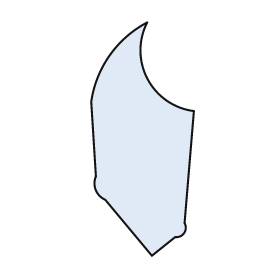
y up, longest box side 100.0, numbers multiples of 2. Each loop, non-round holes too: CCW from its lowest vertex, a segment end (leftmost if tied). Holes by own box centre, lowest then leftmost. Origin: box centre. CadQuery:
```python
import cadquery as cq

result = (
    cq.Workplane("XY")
    .moveTo(4.0, -50.0)
    .lineTo(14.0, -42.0)
    .threePointArc((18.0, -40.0), (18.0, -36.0))
    .lineTo(22.0, 12.0)
    .threePointArc((2.0, 26.0), (2.0, 50.0))
    .threePointArc((-14.0, 36.0), (-22.0, 16.0))
    .lineTo(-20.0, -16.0)
    .threePointArc((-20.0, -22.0), (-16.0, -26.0))
    .close()
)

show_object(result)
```